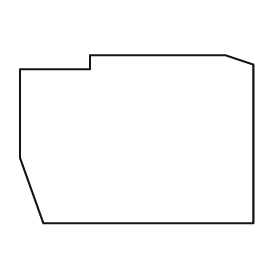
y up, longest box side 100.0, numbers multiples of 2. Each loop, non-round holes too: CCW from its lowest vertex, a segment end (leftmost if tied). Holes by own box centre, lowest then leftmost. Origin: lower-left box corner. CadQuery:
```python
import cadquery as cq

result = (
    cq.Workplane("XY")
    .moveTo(10.0, 0.0)
    .lineTo(100.0, 0.0)
    .lineTo(100.0, 68.0)
    .lineTo(88.0, 72.0)
    .lineTo(30.0, 72.0)
    .lineTo(30.0, 66.0)
    .lineTo(0.0, 66.0)
    .lineTo(0.0, 28.0)
    .close()
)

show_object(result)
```